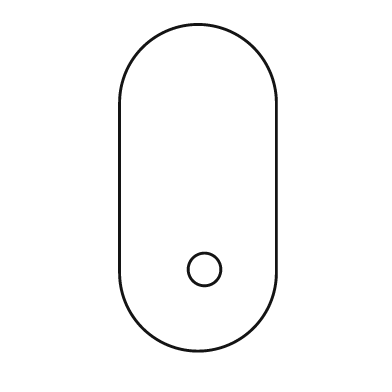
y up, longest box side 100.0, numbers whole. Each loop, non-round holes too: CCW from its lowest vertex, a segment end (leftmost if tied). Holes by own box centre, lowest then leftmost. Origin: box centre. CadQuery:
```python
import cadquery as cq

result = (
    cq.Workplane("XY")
    .moveTo(-24.0, -26.0)
    .threePointArc((0.0, -50.0), (24.0, -26.0))
    .lineTo(24.0, 26.0)
    .threePointArc((0.0, 50.0), (-24.0, 26.0))
    .close()
    .moveTo(2.0, -25.0)
    .circle(5.0)
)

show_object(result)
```